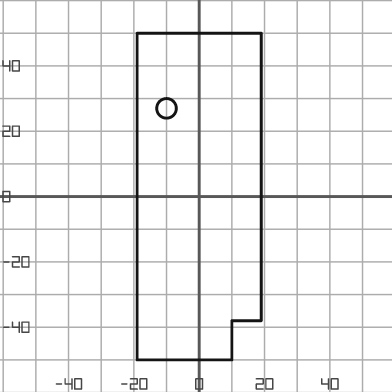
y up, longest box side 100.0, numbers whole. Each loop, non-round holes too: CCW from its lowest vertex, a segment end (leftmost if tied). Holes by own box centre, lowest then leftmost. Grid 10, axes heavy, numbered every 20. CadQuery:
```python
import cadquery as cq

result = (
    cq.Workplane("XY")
    .moveTo(-19.0, -50.0)
    .lineTo(10.0, -50.0)
    .lineTo(10.0, -38.0)
    .lineTo(19.0, -38.0)
    .lineTo(19.0, 50.0)
    .lineTo(-19.0, 50.0)
    .close()
    .moveTo(-10.0, 27.0)
    .circle(3.0)
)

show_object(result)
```